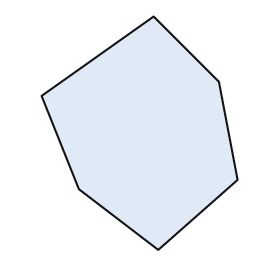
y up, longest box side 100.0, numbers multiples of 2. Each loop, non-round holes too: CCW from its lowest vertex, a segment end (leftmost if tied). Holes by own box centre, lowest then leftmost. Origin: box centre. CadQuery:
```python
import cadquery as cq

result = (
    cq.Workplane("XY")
    .moveTo(8.0, -50.0)
    .lineTo(42.0, -20.0)
    .lineTo(34.0, 22.0)
    .lineTo(6.0, 50.0)
    .lineTo(-42.0, 16.0)
    .lineTo(-26.0, -24.0)
    .close()
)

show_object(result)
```